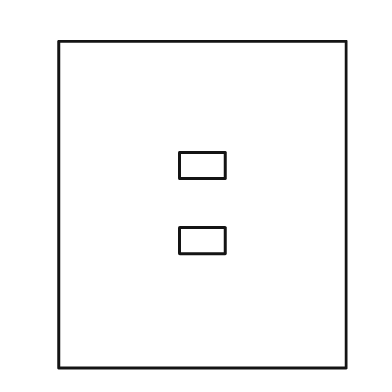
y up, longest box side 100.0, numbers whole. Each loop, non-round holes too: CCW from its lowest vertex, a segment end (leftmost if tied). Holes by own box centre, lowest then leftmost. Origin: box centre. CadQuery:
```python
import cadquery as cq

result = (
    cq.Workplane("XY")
    .moveTo(-44.0, -50.0)
    .lineTo(44.0, -50.0)
    .lineTo(44.0, 50.0)
    .lineTo(-44.0, 50.0)
    .close()
    .moveTo(-7.0, -15.0)
    .lineTo(7.0, -15.0)
    .lineTo(7.0, -7.0)
    .lineTo(-7.0, -7.0)
    .close()
    .moveTo(-7.0, 8.0)
    .lineTo(7.0, 8.0)
    .lineTo(7.0, 16.0)
    .lineTo(-7.0, 16.0)
    .close()
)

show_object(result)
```